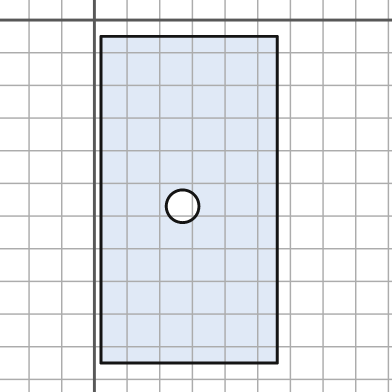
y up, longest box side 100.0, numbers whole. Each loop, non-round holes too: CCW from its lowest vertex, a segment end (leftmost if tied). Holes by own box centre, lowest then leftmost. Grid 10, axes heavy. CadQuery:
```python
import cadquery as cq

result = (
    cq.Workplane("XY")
    .moveTo(2.0, -105.0)
    .lineTo(56.0, -105.0)
    .lineTo(56.0, -5.0)
    .lineTo(2.0, -5.0)
    .close()
    .moveTo(27.0, -57.0)
    .circle(5.0)
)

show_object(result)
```